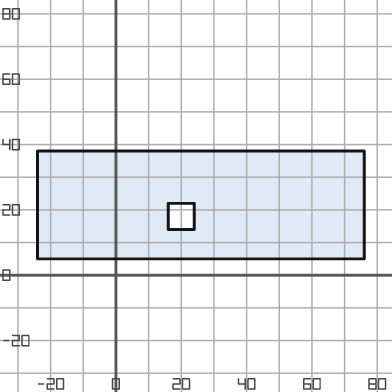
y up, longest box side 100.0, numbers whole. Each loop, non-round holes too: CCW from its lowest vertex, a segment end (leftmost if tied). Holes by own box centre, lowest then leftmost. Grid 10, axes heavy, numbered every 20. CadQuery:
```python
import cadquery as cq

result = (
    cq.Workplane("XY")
    .moveTo(-24.0, 5.0)
    .lineTo(76.0, 5.0)
    .lineTo(76.0, 38.0)
    .lineTo(-24.0, 38.0)
    .close()
    .moveTo(16.0, 14.0)
    .lineTo(24.0, 14.0)
    .lineTo(24.0, 22.0)
    .lineTo(16.0, 22.0)
    .close()
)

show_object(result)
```